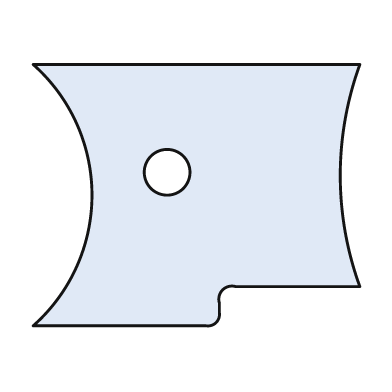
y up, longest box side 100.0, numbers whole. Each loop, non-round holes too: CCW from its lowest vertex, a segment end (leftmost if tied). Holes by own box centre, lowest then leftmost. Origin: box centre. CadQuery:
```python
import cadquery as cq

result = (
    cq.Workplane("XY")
    .moveTo(-50.0, -40.0)
    .lineTo(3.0, -40.0)
    .threePointArc((6.0, -39.0), (7.0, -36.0))
    .lineTo(7.0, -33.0)
    .threePointArc((8.0, -29.0), (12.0, -28.0))
    .lineTo(50.0, -28.0)
    .threePointArc((44.0, 6.0), (50.0, 40.0))
    .lineTo(-50.0, 40.0)
    .threePointArc((-32.0, 0.0), (-50.0, -40.0))
    .close()
    .moveTo(-9.0, 7.0)
    .circle(7.0)
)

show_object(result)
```